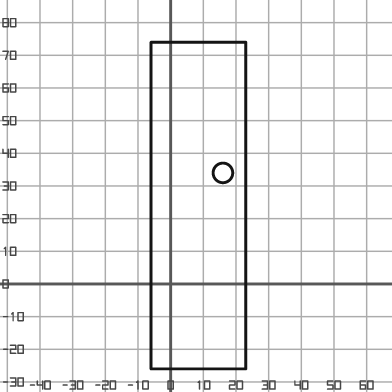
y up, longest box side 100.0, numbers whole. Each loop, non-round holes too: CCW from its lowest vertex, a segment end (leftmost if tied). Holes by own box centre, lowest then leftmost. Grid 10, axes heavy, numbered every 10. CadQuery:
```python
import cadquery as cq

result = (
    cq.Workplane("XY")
    .moveTo(-6.0, -26.0)
    .lineTo(23.0, -26.0)
    .lineTo(23.0, 74.0)
    .lineTo(-6.0, 74.0)
    .close()
    .moveTo(16.0, 34.0)
    .circle(3.0)
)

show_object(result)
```